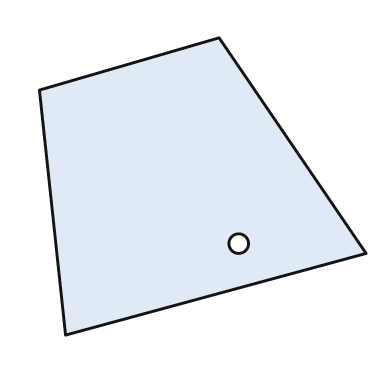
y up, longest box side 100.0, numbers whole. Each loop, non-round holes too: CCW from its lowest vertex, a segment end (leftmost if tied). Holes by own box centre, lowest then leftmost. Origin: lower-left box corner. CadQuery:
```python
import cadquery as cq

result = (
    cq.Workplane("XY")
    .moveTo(8.0, 0.0)
    .lineTo(100.0, 25.0)
    .lineTo(55.0, 91.0)
    .lineTo(0.0, 75.0)
    .close()
    .moveTo(61.0, 28.0)
    .circle(3.0)
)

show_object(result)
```